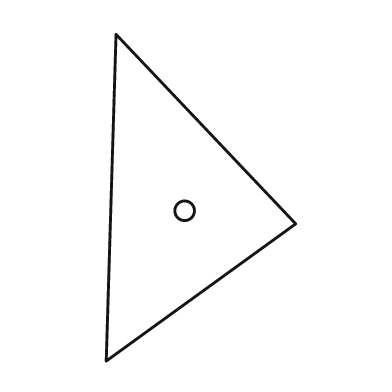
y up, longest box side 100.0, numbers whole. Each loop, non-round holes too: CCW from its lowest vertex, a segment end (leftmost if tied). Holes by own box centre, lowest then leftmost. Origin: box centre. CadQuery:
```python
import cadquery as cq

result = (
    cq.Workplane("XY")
    .moveTo(-29.0, -50.0)
    .lineTo(29.0, -8.0)
    .lineTo(-26.0, 50.0)
    .close()
    .moveTo(-5.0, -4.0)
    .circle(3.0)
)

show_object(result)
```